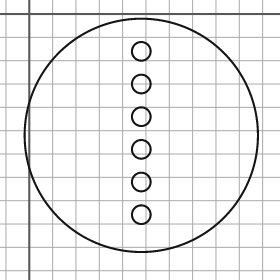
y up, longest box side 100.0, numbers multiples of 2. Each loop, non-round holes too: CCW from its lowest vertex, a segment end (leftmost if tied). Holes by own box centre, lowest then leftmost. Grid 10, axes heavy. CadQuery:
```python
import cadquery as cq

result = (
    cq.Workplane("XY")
    .moveTo(48.0, -52.0)
    .circle(50.0)
    .moveTo(48.0, -86.0)
    .circle(4.0)
    .moveTo(48.0, -72.0)
    .circle(4.0)
    .moveTo(48.0, -58.0)
    .circle(4.0)
    .moveTo(48.0, -44.0)
    .circle(4.0)
    .moveTo(48.0, -30.0)
    .circle(4.0)
    .moveTo(48.0, -16.0)
    .circle(4.0)
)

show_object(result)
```